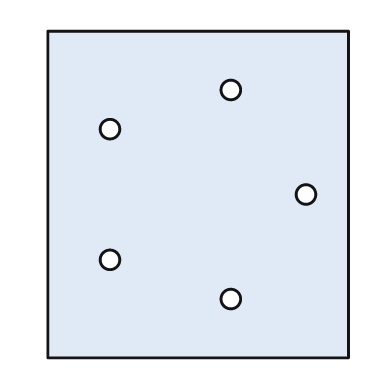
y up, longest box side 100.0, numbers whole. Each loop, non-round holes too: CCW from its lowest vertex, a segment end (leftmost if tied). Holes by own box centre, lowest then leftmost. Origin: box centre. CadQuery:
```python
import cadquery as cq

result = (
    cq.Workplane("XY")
    .moveTo(-46.0, -50.0)
    .lineTo(46.0, -50.0)
    .lineTo(46.0, 50.0)
    .lineTo(-46.0, 50.0)
    .close()
    .moveTo(10.0, -32.0)
    .circle(3.0)
    .moveTo(-27.0, -20.0)
    .circle(3.0)
    .moveTo(33.0, 0.0)
    .circle(3.0)
    .moveTo(-27.0, 20.0)
    .circle(3.0)
    .moveTo(10.0, 32.0)
    .circle(3.0)
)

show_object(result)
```